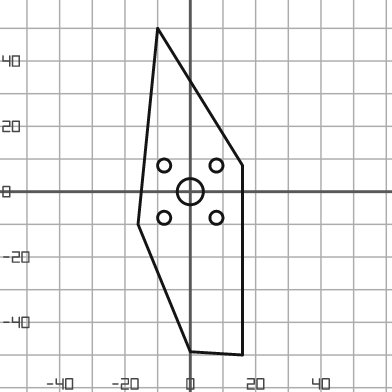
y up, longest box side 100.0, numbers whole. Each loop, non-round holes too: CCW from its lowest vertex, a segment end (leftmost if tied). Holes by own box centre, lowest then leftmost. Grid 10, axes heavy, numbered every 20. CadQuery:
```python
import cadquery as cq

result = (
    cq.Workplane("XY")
    .moveTo(16.0, -50.0)
    .lineTo(16.0, 8.0)
    .lineTo(-10.0, 50.0)
    .lineTo(-16.0, -10.0)
    .lineTo(0.0, -49.0)
    .close()
    .moveTo(-8.0, -8.0)
    .circle(2.0)
    .moveTo(8.0, -8.0)
    .circle(2.0)
    .moveTo(0.0, 0.0)
    .circle(4.0)
    .moveTo(-8.0, 8.0)
    .circle(2.0)
    .moveTo(8.0, 8.0)
    .circle(2.0)
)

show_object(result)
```